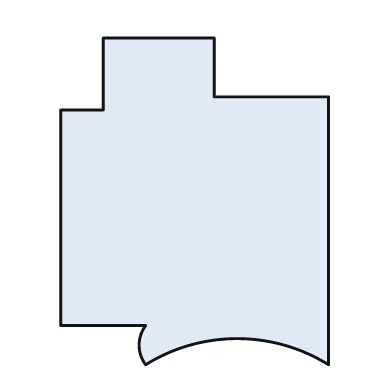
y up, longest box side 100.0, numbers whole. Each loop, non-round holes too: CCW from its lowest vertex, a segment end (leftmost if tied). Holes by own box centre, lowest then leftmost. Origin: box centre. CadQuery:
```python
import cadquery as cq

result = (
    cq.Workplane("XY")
    .moveTo(-15.0, -50.0)
    .threePointArc((13.0, -42.0), (41.0, -50.0))
    .lineTo(41.0, 32.0)
    .lineTo(6.0, 32.0)
    .lineTo(6.0, 50.0)
    .lineTo(-28.0, 50.0)
    .lineTo(-28.0, 28.0)
    .lineTo(-41.0, 28.0)
    .lineTo(-41.0, -38.0)
    .lineTo(-15.0, -38.0)
    .threePointArc((-17.0, -44.0), (-15.0, -50.0))
    .close()
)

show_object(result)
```